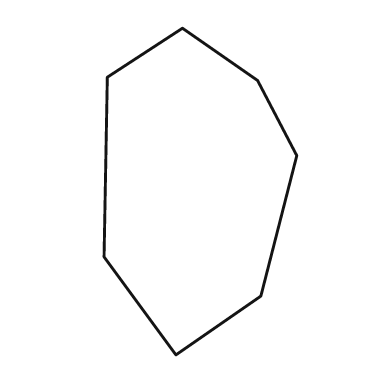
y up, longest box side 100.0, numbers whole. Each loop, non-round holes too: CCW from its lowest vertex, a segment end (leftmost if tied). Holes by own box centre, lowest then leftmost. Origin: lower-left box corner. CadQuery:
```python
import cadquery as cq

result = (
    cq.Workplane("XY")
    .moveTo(22.0, 0.0)
    .lineTo(48.0, 18.0)
    .lineTo(59.0, 61.0)
    .lineTo(47.0, 84.0)
    .lineTo(24.0, 100.0)
    .lineTo(1.0, 85.0)
    .lineTo(0.0, 30.0)
    .close()
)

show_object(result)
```